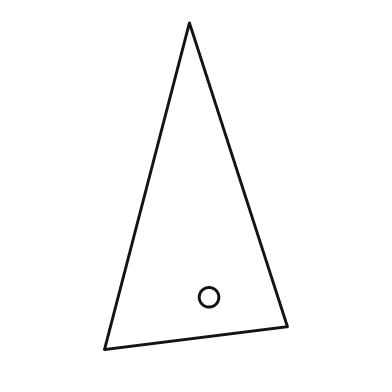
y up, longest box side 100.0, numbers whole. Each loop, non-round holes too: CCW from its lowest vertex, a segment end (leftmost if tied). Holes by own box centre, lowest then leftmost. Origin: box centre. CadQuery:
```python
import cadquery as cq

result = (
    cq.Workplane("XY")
    .moveTo(-28.0, -50.0)
    .lineTo(28.0, -43.0)
    .lineTo(-2.0, 50.0)
    .close()
    .moveTo(4.0, -34.0)
    .circle(3.0)
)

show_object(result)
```